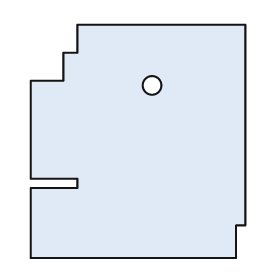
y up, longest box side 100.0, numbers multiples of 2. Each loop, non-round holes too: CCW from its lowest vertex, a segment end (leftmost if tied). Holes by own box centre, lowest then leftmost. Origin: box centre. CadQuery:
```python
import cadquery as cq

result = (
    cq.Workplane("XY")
    .moveTo(-46.0, -50.0)
    .lineTo(42.0, -50.0)
    .lineTo(42.0, -36.0)
    .lineTo(46.0, -36.0)
    .lineTo(46.0, 50.0)
    .lineTo(-26.0, 50.0)
    .lineTo(-26.0, 38.0)
    .lineTo(-32.0, 38.0)
    .lineTo(-32.0, 26.0)
    .lineTo(-46.0, 26.0)
    .lineTo(-46.0, -16.0)
    .lineTo(-26.0, -16.0)
    .lineTo(-26.0, -20.0)
    .lineTo(-46.0, -20.0)
    .close()
    .moveTo(6.0, 24.0)
    .circle(4.0)
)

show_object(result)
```